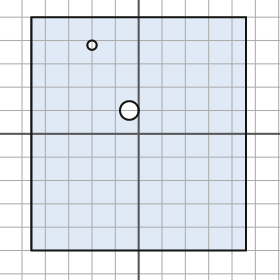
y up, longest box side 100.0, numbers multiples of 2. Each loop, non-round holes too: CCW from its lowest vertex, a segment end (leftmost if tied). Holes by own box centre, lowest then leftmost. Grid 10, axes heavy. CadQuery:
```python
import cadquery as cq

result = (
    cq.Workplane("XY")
    .moveTo(-46.0, -50.0)
    .lineTo(46.0, -50.0)
    .lineTo(46.0, 50.0)
    .lineTo(-46.0, 50.0)
    .close()
    .moveTo(-4.0, 10.0)
    .circle(4.0)
    .moveTo(-20.0, 38.0)
    .circle(2.0)
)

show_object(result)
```